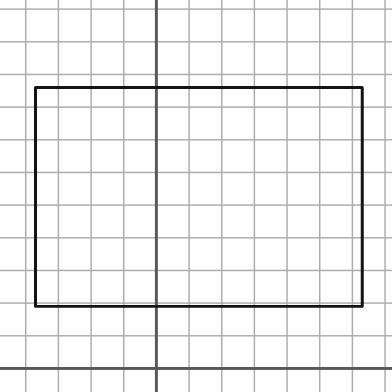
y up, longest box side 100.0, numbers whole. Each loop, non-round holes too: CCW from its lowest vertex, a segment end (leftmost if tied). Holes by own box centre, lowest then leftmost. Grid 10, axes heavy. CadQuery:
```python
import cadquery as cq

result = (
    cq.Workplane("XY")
    .moveTo(-37.0, 19.0)
    .lineTo(63.0, 19.0)
    .lineTo(63.0, 86.0)
    .lineTo(-37.0, 86.0)
    .close()
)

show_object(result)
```